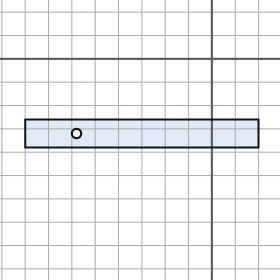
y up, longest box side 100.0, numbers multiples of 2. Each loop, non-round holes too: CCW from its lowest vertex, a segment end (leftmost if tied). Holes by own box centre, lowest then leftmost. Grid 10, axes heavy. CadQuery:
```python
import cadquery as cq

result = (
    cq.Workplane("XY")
    .moveTo(-80.0, -38.0)
    .lineTo(20.0, -38.0)
    .lineTo(20.0, -26.0)
    .lineTo(-80.0, -26.0)
    .close()
    .moveTo(-58.0, -32.0)
    .circle(2.0)
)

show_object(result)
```